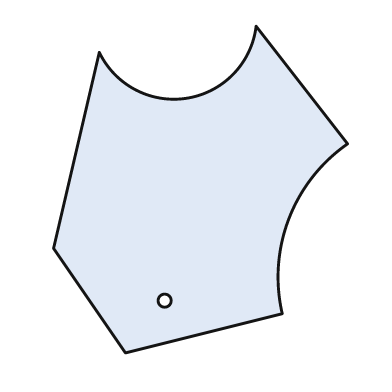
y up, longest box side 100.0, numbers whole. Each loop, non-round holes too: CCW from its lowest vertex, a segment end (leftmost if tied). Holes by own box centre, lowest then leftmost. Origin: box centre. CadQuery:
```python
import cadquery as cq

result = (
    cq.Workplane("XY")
    .moveTo(-23.0, -50.0)
    .lineTo(25.0, -38.0)
    .threePointArc((27.0, -9.0), (45.0, 14.0))
    .lineTo(17.0, 50.0)
    .threePointArc((-4.0, 28.0), (-31.0, 42.0))
    .lineTo(-45.0, -18.0)
    .close()
    .moveTo(-11.0, -34.0)
    .circle(2.0)
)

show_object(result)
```